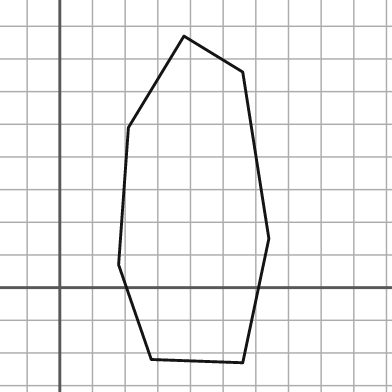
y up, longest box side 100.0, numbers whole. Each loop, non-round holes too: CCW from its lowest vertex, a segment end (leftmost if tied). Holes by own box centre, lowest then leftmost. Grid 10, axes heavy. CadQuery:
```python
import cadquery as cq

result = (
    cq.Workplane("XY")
    .moveTo(56.0, -23.0)
    .lineTo(64.0, 15.0)
    .lineTo(56.0, 66.0)
    .lineTo(38.0, 77.0)
    .lineTo(21.0, 49.0)
    .lineTo(18.0, 7.0)
    .lineTo(28.0, -22.0)
    .close()
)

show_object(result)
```